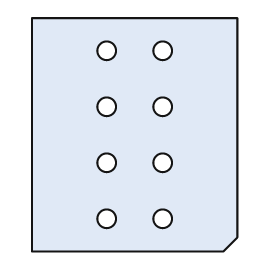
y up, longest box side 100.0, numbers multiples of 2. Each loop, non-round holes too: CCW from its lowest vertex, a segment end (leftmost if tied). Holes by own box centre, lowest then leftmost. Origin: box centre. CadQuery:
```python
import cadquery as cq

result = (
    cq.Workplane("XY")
    .moveTo(-44.0, -50.0)
    .lineTo(38.0, -50.0)
    .lineTo(44.0, -44.0)
    .lineTo(44.0, 50.0)
    .lineTo(-44.0, 50.0)
    .close()
    .moveTo(-12.0, -36.0)
    .circle(4.0)
    .moveTo(12.0, -36.0)
    .circle(4.0)
    .moveTo(-12.0, -12.0)
    .circle(4.0)
    .moveTo(12.0, -12.0)
    .circle(4.0)
    .moveTo(-12.0, 12.0)
    .circle(4.0)
    .moveTo(12.0, 12.0)
    .circle(4.0)
    .moveTo(-12.0, 36.0)
    .circle(4.0)
    .moveTo(12.0, 36.0)
    .circle(4.0)
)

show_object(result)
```